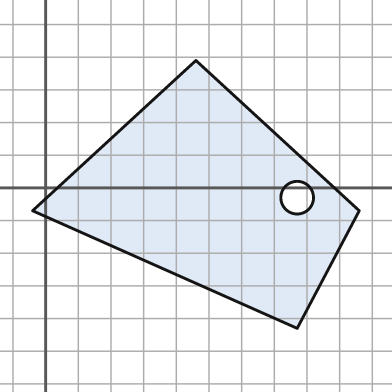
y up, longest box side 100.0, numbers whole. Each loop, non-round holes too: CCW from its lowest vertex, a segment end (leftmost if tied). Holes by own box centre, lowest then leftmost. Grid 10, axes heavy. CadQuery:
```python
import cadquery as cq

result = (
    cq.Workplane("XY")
    .moveTo(77.0, -43.0)
    .lineTo(96.0, -7.0)
    .lineTo(46.0, 39.0)
    .lineTo(-4.0, -7.0)
    .close()
    .moveTo(77.0, -3.0)
    .circle(5.0)
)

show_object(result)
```